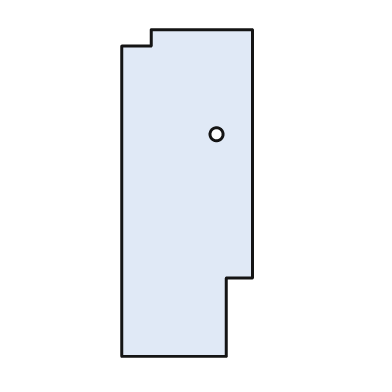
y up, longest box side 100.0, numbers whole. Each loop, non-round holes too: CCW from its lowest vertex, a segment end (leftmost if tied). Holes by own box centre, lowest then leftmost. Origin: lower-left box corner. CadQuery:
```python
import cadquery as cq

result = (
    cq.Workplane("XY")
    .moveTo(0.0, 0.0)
    .lineTo(32.0, 0.0)
    .lineTo(32.0, 24.0)
    .lineTo(40.0, 24.0)
    .lineTo(40.0, 100.0)
    .lineTo(9.0, 100.0)
    .lineTo(9.0, 95.0)
    .lineTo(0.0, 95.0)
    .close()
    .moveTo(29.0, 68.0)
    .circle(2.0)
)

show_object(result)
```